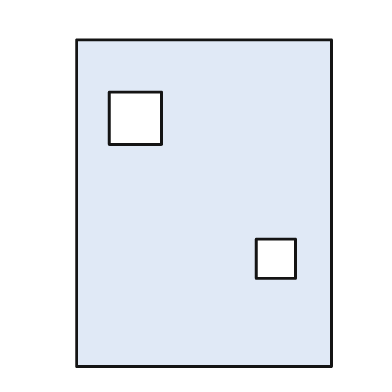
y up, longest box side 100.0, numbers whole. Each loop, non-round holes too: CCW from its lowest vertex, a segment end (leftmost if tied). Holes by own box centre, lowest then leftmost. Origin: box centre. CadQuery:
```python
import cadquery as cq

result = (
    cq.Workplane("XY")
    .moveTo(-39.0, -50.0)
    .lineTo(39.0, -50.0)
    .lineTo(39.0, 50.0)
    .lineTo(-39.0, 50.0)
    .close()
    .moveTo(16.0, -23.0)
    .lineTo(28.0, -23.0)
    .lineTo(28.0, -11.0)
    .lineTo(16.0, -11.0)
    .close()
    .moveTo(-29.0, 18.0)
    .lineTo(-13.0, 18.0)
    .lineTo(-13.0, 34.0)
    .lineTo(-29.0, 34.0)
    .close()
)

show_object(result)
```